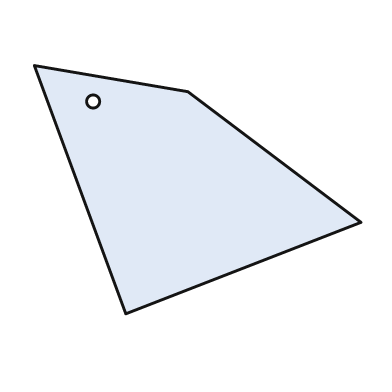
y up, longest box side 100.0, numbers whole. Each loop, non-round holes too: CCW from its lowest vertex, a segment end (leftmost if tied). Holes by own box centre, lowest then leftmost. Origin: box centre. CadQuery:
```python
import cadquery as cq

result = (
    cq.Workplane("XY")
    .moveTo(-22.0, -38.0)
    .lineTo(50.0, -10.0)
    .lineTo(-3.0, 30.0)
    .lineTo(-50.0, 38.0)
    .close()
    .moveTo(-32.0, 27.0)
    .circle(2.0)
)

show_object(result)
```